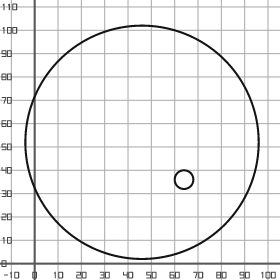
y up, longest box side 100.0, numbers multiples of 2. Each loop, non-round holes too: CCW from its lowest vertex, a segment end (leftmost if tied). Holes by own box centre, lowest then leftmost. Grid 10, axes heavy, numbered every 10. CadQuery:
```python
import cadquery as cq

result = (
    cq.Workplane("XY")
    .moveTo(46.0, 52.0)
    .circle(50.0)
    .moveTo(64.0, 36.0)
    .circle(4.0)
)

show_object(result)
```